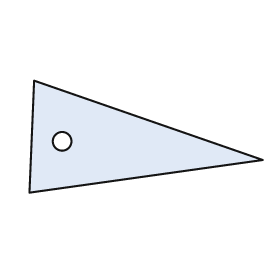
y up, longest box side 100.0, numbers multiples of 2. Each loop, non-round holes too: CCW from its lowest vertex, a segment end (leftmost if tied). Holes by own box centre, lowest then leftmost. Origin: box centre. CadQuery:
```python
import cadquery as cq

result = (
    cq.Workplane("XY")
    .moveTo(-50.0, -24.0)
    .lineTo(50.0, -10.0)
    .lineTo(-48.0, 24.0)
    .close()
    .moveTo(-36.0, -2.0)
    .circle(4.0)
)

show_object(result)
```